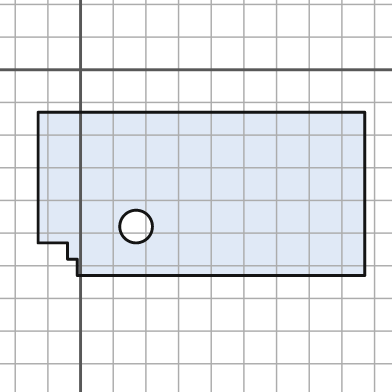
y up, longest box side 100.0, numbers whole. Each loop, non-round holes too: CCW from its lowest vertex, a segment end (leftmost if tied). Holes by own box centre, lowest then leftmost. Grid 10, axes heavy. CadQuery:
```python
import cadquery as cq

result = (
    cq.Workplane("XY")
    .moveTo(-1.0, -63.0)
    .lineTo(87.0, -63.0)
    .lineTo(87.0, -13.0)
    .lineTo(-13.0, -13.0)
    .lineTo(-13.0, -53.0)
    .lineTo(-4.0, -53.0)
    .lineTo(-4.0, -58.0)
    .lineTo(-1.0, -58.0)
    .close()
    .moveTo(17.0, -48.0)
    .circle(5.0)
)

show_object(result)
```